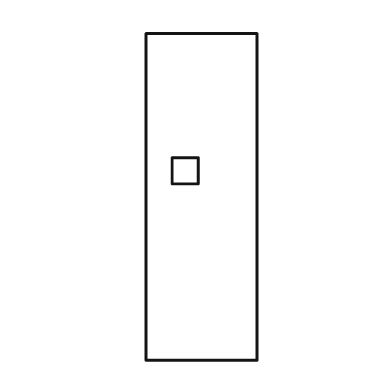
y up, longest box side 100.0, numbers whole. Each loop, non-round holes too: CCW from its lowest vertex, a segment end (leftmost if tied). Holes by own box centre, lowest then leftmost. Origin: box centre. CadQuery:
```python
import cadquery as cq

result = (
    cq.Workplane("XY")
    .moveTo(-17.0, -50.0)
    .lineTo(17.0, -50.0)
    .lineTo(17.0, 50.0)
    .lineTo(-17.0, 50.0)
    .close()
    .moveTo(-9.0, 4.0)
    .lineTo(-1.0, 4.0)
    .lineTo(-1.0, 12.0)
    .lineTo(-9.0, 12.0)
    .close()
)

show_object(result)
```